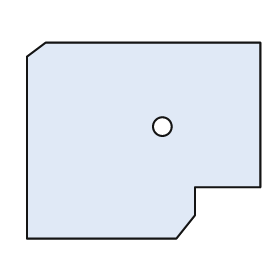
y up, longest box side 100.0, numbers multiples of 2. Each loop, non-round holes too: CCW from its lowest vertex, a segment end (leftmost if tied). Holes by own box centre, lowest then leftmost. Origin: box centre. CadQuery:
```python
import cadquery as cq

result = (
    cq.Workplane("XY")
    .moveTo(-50.0, -42.0)
    .lineTo(14.0, -42.0)
    .lineTo(22.0, -32.0)
    .lineTo(22.0, -20.0)
    .lineTo(50.0, -20.0)
    .lineTo(50.0, 42.0)
    .lineTo(-42.0, 42.0)
    .lineTo(-50.0, 36.0)
    .close()
    .moveTo(8.0, 6.0)
    .circle(4.0)
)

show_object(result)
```